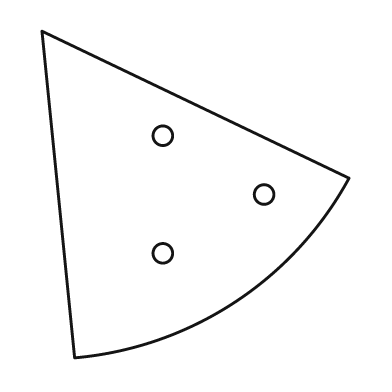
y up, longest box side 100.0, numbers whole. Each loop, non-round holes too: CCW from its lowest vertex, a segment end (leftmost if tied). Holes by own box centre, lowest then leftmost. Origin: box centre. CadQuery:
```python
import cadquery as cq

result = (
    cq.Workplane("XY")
    .moveTo(-37.0, -50.0)
    .threePointArc((12.0, -33.0), (47.0, 5.0))
    .lineTo(-47.0, 50.0)
    .close()
    .moveTo(-10.0, -18.0)
    .circle(3.0)
    .moveTo(21.0, 0.0)
    .circle(3.0)
    .moveTo(-10.0, 18.0)
    .circle(3.0)
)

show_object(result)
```